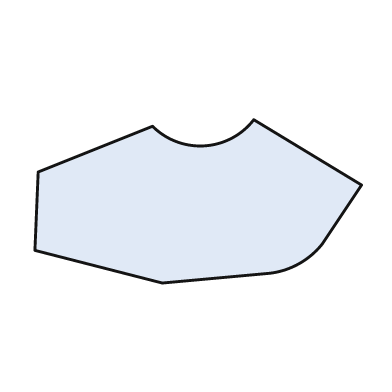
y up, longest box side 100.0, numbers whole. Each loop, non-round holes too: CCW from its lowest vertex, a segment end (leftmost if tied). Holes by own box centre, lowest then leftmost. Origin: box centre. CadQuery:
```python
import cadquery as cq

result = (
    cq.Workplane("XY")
    .moveTo(-11.0, -25.0)
    .lineTo(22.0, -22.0)
    .threePointArc((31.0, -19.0), (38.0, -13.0))
    .lineTo(50.0, 5.0)
    .lineTo(17.0, 25.0)
    .threePointArc((2.0, 17.0), (-14.0, 23.0))
    .lineTo(-49.0, 9.0)
    .lineTo(-50.0, -15.0)
    .close()
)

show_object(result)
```